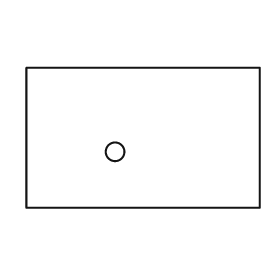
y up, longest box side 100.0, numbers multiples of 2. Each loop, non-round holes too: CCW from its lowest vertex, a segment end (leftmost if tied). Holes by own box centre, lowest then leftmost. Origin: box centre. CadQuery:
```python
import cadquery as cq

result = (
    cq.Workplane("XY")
    .moveTo(-50.0, -30.0)
    .lineTo(50.0, -30.0)
    .lineTo(50.0, 30.0)
    .lineTo(-50.0, 30.0)
    .close()
    .moveTo(-12.0, -6.0)
    .circle(4.0)
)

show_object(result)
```